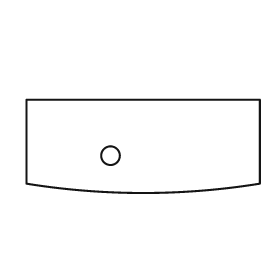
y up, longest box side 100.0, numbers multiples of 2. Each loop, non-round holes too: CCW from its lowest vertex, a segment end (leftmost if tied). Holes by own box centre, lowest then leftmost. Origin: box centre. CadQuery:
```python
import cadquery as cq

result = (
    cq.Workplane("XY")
    .moveTo(-50.0, -16.0)
    .threePointArc((0.0, -20.0), (50.0, -16.0))
    .lineTo(50.0, 20.0)
    .lineTo(-50.0, 20.0)
    .close()
    .moveTo(-14.0, -4.0)
    .circle(4.0)
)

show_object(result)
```